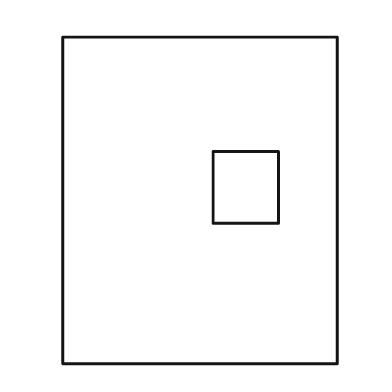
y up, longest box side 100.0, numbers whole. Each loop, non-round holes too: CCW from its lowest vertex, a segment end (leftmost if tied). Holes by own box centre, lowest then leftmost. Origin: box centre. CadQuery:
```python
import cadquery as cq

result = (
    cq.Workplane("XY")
    .moveTo(-42.0, -50.0)
    .lineTo(42.0, -50.0)
    .lineTo(42.0, 50.0)
    .lineTo(-42.0, 50.0)
    .close()
    .moveTo(4.0, -7.0)
    .lineTo(24.0, -7.0)
    .lineTo(24.0, 15.0)
    .lineTo(4.0, 15.0)
    .close()
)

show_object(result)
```